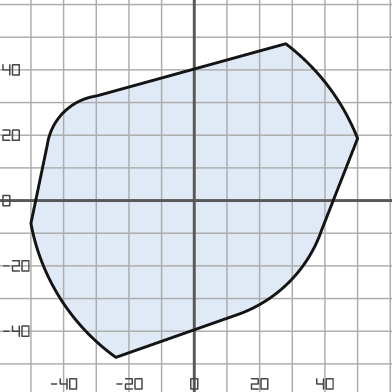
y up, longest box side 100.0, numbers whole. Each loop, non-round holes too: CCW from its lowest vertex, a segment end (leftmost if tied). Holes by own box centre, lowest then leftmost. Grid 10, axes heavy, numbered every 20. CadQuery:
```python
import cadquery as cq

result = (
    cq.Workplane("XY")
    .moveTo(-24.0, -48.0)
    .lineTo(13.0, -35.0)
    .threePointArc((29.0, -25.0), (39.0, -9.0))
    .lineTo(50.0, 19.0)
    .threePointArc((41.0, 35.0), (28.0, 48.0))
    .lineTo(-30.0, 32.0)
    .threePointArc((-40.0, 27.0), (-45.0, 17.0))
    .lineTo(-50.0, -7.0)
    .threePointArc((-41.0, -30.0), (-24.0, -48.0))
    .close()
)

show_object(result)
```